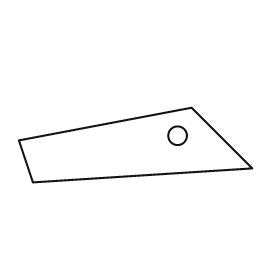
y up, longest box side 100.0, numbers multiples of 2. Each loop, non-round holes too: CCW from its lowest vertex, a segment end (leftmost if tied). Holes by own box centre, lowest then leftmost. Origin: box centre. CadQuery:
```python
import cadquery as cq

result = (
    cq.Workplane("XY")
    .moveTo(-44.0, -16.0)
    .lineTo(50.0, -10.0)
    .lineTo(24.0, 16.0)
    .lineTo(-50.0, 2.0)
    .close()
    .moveTo(18.0, 4.0)
    .circle(4.0)
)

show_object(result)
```